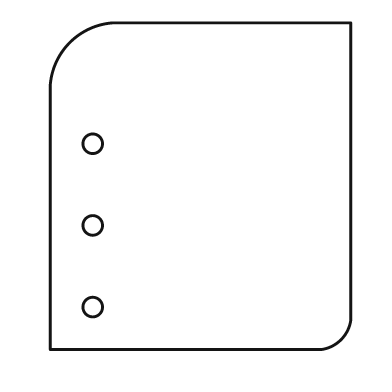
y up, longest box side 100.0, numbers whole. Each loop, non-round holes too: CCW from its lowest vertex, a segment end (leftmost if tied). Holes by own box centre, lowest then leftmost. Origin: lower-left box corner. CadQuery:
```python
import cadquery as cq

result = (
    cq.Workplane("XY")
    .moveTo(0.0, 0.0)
    .lineTo(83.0, 0.0)
    .threePointArc((89.0, 3.0), (92.0, 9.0))
    .lineTo(92.0, 100.0)
    .lineTo(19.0, 100.0)
    .threePointArc((6.0, 94.0), (0.0, 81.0))
    .close()
    .moveTo(13.0, 13.0)
    .circle(3.0)
    .moveTo(13.0, 38.0)
    .circle(3.0)
    .moveTo(13.0, 63.0)
    .circle(3.0)
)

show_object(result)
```